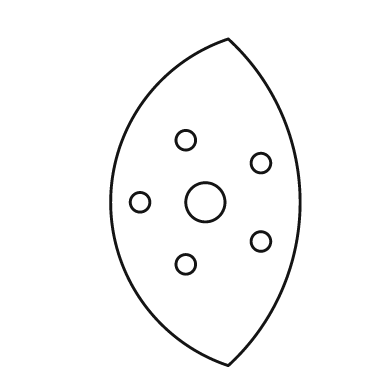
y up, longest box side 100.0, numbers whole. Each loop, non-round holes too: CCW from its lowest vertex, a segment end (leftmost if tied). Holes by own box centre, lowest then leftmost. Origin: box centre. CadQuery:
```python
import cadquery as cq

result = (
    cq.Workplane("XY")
    .moveTo(7.0, -50.0)
    .threePointArc((29.0, 0.0), (7.0, 50.0))
    .threePointArc((-29.0, 0.0), (7.0, -50.0))
    .close()
    .moveTo(-6.0, -19.0)
    .circle(3.0)
    .moveTo(17.0, -12.0)
    .circle(3.0)
    .moveTo(-20.0, 0.0)
    .circle(3.0)
    .moveTo(0.0, 0.0)
    .circle(6.0)
    .moveTo(17.0, 12.0)
    .circle(3.0)
    .moveTo(-6.0, 19.0)
    .circle(3.0)
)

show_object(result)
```